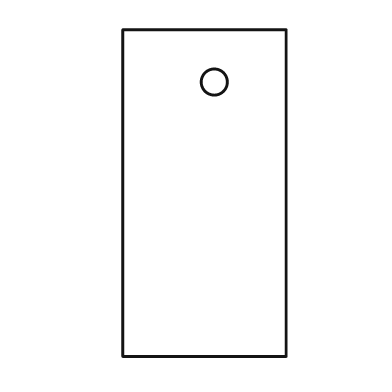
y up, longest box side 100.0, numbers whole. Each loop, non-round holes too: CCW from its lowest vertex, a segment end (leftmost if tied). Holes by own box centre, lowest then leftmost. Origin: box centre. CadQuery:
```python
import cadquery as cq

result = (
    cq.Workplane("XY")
    .moveTo(-25.0, -50.0)
    .lineTo(25.0, -50.0)
    .lineTo(25.0, 50.0)
    .lineTo(-25.0, 50.0)
    .close()
    .moveTo(3.0, 34.0)
    .circle(4.0)
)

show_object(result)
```